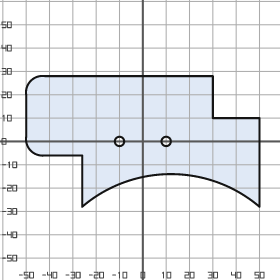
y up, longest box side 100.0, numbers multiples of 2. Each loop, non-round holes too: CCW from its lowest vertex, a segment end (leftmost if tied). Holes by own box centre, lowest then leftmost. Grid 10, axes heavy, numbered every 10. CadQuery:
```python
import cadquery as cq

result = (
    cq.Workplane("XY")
    .moveTo(-26.0, -28.0)
    .threePointArc((12.0, -14.0), (50.0, -28.0))
    .lineTo(50.0, 10.0)
    .lineTo(30.0, 10.0)
    .lineTo(30.0, 28.0)
    .lineTo(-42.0, 28.0)
    .threePointArc((-48.0, 26.0), (-50.0, 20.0))
    .lineTo(-50.0, 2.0)
    .threePointArc((-48.0, -4.0), (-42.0, -6.0))
    .lineTo(-26.0, -6.0)
    .close()
    .moveTo(-10.0, 0.0)
    .circle(2.0)
    .moveTo(10.0, 0.0)
    .circle(2.0)
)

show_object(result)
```